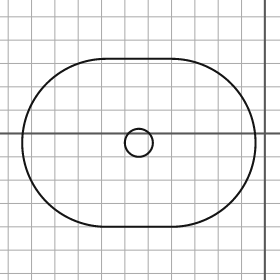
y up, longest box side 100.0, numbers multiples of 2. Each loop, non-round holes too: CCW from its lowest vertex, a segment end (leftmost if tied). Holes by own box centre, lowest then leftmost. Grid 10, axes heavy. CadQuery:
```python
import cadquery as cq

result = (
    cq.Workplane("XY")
    .moveTo(-68.0, -40.0)
    .lineTo(-40.0, -40.0)
    .threePointArc((-4.0, -4.0), (-40.0, 32.0))
    .lineTo(-68.0, 32.0)
    .threePointArc((-104.0, -4.0), (-68.0, -40.0))
    .close()
    .moveTo(-54.0, -4.0)
    .circle(6.0)
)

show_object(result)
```